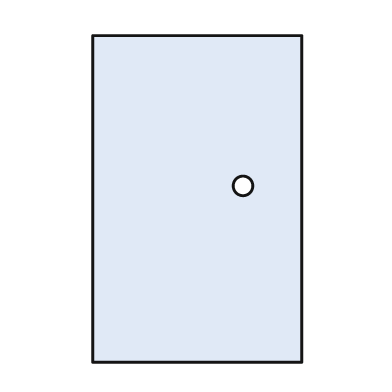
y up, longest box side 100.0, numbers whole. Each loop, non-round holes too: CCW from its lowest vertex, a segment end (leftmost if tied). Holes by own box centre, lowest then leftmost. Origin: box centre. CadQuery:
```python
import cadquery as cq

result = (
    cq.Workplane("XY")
    .moveTo(-32.0, -50.0)
    .lineTo(32.0, -50.0)
    .lineTo(32.0, 50.0)
    .lineTo(-32.0, 50.0)
    .close()
    .moveTo(14.0, 4.0)
    .circle(3.0)
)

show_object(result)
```